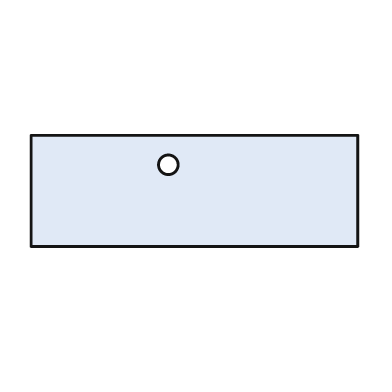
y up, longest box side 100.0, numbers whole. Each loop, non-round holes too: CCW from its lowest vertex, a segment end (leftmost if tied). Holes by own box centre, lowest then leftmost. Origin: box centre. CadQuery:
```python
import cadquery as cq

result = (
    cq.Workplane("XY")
    .moveTo(-50.0, -17.0)
    .lineTo(50.0, -17.0)
    .lineTo(50.0, 17.0)
    .lineTo(-50.0, 17.0)
    .close()
    .moveTo(-8.0, 8.0)
    .circle(3.0)
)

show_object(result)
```